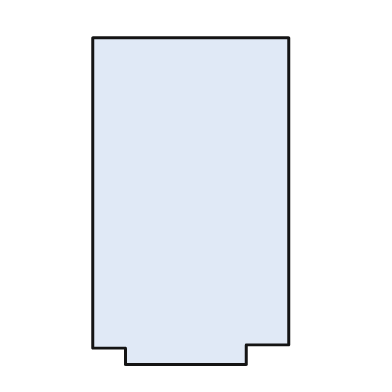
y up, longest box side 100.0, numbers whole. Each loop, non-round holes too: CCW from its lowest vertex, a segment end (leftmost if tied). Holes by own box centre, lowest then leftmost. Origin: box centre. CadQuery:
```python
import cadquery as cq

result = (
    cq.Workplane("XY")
    .moveTo(-20.0, -50.0)
    .lineTo(17.0, -50.0)
    .lineTo(17.0, -44.0)
    .lineTo(30.0, -44.0)
    .lineTo(30.0, 50.0)
    .lineTo(-30.0, 50.0)
    .lineTo(-30.0, -45.0)
    .lineTo(-20.0, -45.0)
    .close()
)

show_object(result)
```